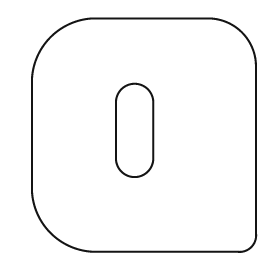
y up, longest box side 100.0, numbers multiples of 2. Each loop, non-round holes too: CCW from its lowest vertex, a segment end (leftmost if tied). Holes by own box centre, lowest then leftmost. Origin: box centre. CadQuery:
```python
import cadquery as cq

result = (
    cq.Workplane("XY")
    .moveTo(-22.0, -50.0)
    .lineTo(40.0, -50.0)
    .threePointArc((46.0, -48.0), (48.0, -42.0))
    .lineTo(48.0, 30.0)
    .threePointArc((42.0, 44.0), (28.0, 50.0))
    .lineTo(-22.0, 50.0)
    .threePointArc((-40.0, 42.0), (-48.0, 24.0))
    .lineTo(-48.0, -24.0)
    .threePointArc((-40.0, -42.0), (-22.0, -50.0))
    .close()
    .moveTo(-12.0, -10.0)
    .threePointArc((-4.0, -18.0), (4.0, -10.0))
    .lineTo(4.0, 14.0)
    .threePointArc((-4.0, 22.0), (-12.0, 14.0))
    .close()
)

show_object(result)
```